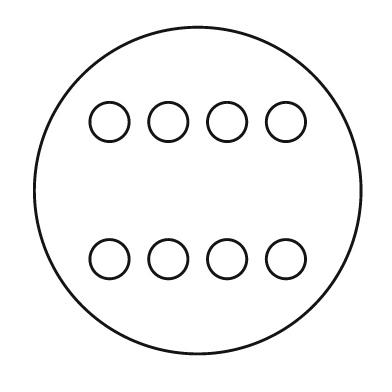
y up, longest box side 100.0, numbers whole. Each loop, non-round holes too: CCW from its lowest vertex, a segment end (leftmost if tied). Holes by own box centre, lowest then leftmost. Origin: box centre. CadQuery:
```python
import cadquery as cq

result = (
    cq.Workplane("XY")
    .moveTo(0.0, 0.0)
    .circle(50.0)
    .moveTo(-27.0, -21.0)
    .circle(6.0)
    .moveTo(-9.0, -21.0)
    .circle(6.0)
    .moveTo(9.0, -21.0)
    .circle(6.0)
    .moveTo(27.0, -21.0)
    .circle(6.0)
    .moveTo(-27.0, 21.0)
    .circle(6.0)
    .moveTo(-9.0, 21.0)
    .circle(6.0)
    .moveTo(9.0, 21.0)
    .circle(6.0)
    .moveTo(27.0, 21.0)
    .circle(6.0)
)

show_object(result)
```